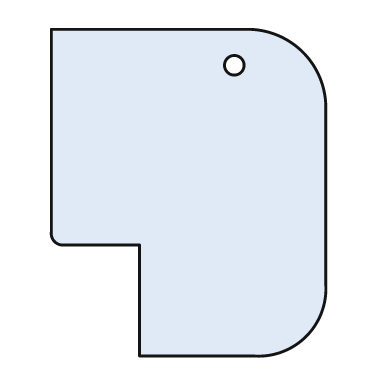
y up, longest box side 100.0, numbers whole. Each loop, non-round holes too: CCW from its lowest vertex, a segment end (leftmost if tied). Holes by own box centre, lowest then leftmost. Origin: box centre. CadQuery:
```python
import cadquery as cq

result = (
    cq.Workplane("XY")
    .moveTo(-15.0, -50.0)
    .lineTo(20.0, -50.0)
    .threePointArc((36.0, -44.0), (42.0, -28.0))
    .lineTo(42.0, 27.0)
    .threePointArc((35.0, 43.0), (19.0, 50.0))
    .lineTo(-42.0, 50.0)
    .lineTo(-42.0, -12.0)
    .threePointArc((-41.0, -15.0), (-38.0, -16.0))
    .lineTo(-15.0, -16.0)
    .close()
    .moveTo(14.0, 39.0)
    .circle(3.0)
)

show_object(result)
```